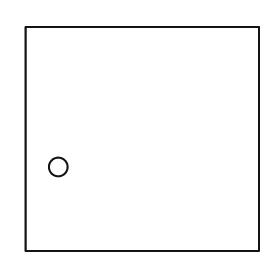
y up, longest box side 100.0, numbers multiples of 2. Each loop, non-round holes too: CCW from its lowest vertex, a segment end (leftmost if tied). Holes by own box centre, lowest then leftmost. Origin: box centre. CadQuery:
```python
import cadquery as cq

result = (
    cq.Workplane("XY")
    .moveTo(-50.0, -48.0)
    .lineTo(50.0, -48.0)
    .lineTo(50.0, 48.0)
    .lineTo(-50.0, 48.0)
    .close()
    .moveTo(-36.0, -12.0)
    .circle(4.0)
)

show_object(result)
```